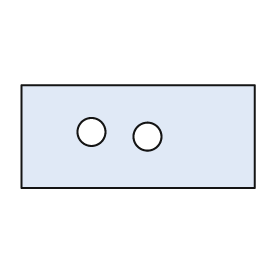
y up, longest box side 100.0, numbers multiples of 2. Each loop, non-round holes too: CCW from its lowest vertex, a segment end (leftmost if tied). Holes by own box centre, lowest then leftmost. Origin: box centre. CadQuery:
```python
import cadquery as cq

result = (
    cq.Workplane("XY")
    .moveTo(-50.0, -22.0)
    .lineTo(50.0, -22.0)
    .lineTo(50.0, 22.0)
    .lineTo(-50.0, 22.0)
    .close()
    .moveTo(4.0, 0.0)
    .circle(6.0)
    .moveTo(-20.0, 2.0)
    .circle(6.0)
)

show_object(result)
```